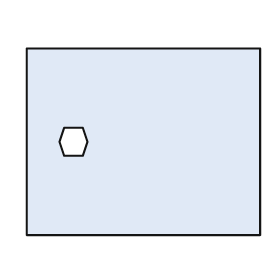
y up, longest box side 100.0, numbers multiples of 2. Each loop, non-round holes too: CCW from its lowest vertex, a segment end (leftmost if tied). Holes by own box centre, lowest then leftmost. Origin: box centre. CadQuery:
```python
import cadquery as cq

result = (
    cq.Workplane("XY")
    .moveTo(-50.0, -40.0)
    .lineTo(50.0, -40.0)
    .lineTo(50.0, 40.0)
    .lineTo(-50.0, 40.0)
    .close()
    .moveTo(-34.0, -6.0)
    .lineTo(-26.0, -6.0)
    .lineTo(-24.0, 0.0)
    .lineTo(-26.0, 6.0)
    .lineTo(-34.0, 6.0)
    .lineTo(-36.0, 0.0)
    .close()
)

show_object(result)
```